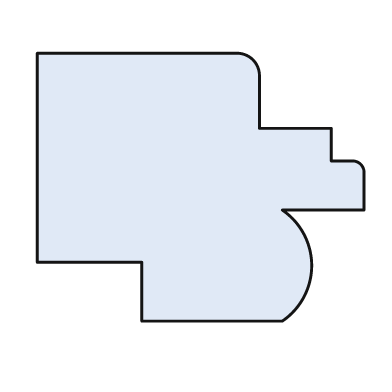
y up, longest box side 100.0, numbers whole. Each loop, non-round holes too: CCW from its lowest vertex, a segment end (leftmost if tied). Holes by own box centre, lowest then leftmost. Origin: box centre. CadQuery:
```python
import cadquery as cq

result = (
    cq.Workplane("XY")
    .moveTo(-18.0, -41.0)
    .lineTo(25.0, -41.0)
    .threePointArc((34.0, -24.0), (25.0, -7.0))
    .lineTo(50.0, -7.0)
    .lineTo(50.0, 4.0)
    .threePointArc((49.0, 7.0), (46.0, 8.0))
    .lineTo(40.0, 8.0)
    .lineTo(40.0, 18.0)
    .lineTo(18.0, 18.0)
    .lineTo(18.0, 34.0)
    .threePointArc((16.0, 39.0), (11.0, 41.0))
    .lineTo(-50.0, 41.0)
    .lineTo(-50.0, -23.0)
    .lineTo(-18.0, -23.0)
    .close()
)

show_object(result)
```